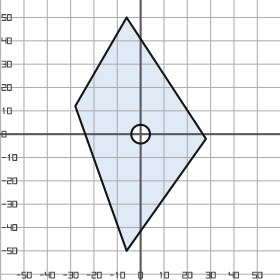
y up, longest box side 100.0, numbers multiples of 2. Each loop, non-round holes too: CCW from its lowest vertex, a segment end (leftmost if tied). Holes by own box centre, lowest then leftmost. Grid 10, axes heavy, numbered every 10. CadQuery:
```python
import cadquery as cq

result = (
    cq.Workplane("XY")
    .moveTo(-6.0, -50.0)
    .lineTo(28.0, -2.0)
    .lineTo(-6.0, 50.0)
    .lineTo(-28.0, 12.0)
    .close()
    .moveTo(0.0, 0.0)
    .circle(4.0)
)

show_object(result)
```